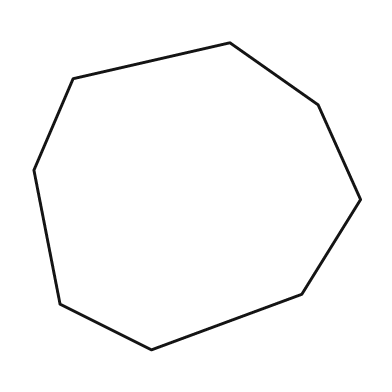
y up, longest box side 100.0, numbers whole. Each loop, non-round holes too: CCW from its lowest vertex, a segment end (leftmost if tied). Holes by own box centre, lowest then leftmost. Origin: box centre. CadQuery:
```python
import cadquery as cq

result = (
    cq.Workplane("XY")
    .moveTo(-14.0, -47.0)
    .lineTo(32.0, -30.0)
    .lineTo(50.0, -1.0)
    .lineTo(37.0, 28.0)
    .lineTo(10.0, 47.0)
    .lineTo(-38.0, 36.0)
    .lineTo(-50.0, 8.0)
    .lineTo(-42.0, -33.0)
    .close()
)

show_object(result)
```